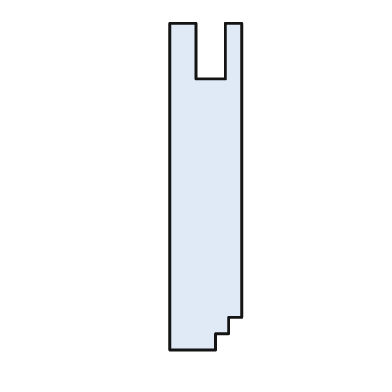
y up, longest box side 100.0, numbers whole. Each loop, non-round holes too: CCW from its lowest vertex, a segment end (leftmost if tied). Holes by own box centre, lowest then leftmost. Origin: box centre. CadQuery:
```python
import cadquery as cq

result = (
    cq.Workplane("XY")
    .moveTo(-11.0, -50.0)
    .lineTo(3.0, -50.0)
    .lineTo(3.0, -45.0)
    .lineTo(7.0, -45.0)
    .lineTo(7.0, -40.0)
    .lineTo(11.0, -40.0)
    .lineTo(11.0, 50.0)
    .lineTo(6.0, 50.0)
    .lineTo(6.0, 33.0)
    .lineTo(-3.0, 33.0)
    .lineTo(-3.0, 50.0)
    .lineTo(-11.0, 50.0)
    .close()
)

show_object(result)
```